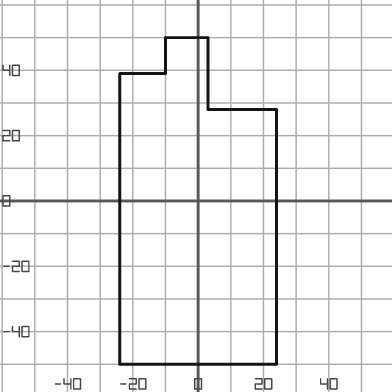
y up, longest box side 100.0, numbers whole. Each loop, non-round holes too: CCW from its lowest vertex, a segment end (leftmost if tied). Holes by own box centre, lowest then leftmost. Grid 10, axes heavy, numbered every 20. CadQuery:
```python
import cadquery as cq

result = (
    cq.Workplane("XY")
    .moveTo(-24.0, -50.0)
    .lineTo(24.0, -50.0)
    .lineTo(24.0, 28.0)
    .lineTo(3.0, 28.0)
    .lineTo(3.0, 50.0)
    .lineTo(-10.0, 50.0)
    .lineTo(-10.0, 39.0)
    .lineTo(-24.0, 39.0)
    .close()
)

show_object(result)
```